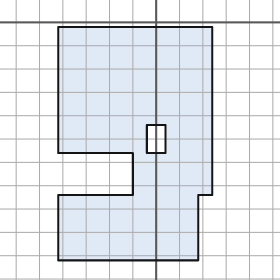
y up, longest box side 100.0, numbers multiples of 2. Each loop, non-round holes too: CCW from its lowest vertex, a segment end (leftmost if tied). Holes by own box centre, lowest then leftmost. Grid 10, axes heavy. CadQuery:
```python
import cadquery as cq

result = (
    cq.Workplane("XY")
    .moveTo(-42.0, -102.0)
    .lineTo(18.0, -102.0)
    .lineTo(18.0, -74.0)
    .lineTo(24.0, -74.0)
    .lineTo(24.0, -2.0)
    .lineTo(-42.0, -2.0)
    .lineTo(-42.0, -56.0)
    .lineTo(-10.0, -56.0)
    .lineTo(-10.0, -74.0)
    .lineTo(-42.0, -74.0)
    .close()
    .moveTo(-4.0, -56.0)
    .lineTo(4.0, -56.0)
    .lineTo(4.0, -44.0)
    .lineTo(-4.0, -44.0)
    .close()
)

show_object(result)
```